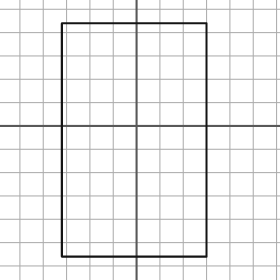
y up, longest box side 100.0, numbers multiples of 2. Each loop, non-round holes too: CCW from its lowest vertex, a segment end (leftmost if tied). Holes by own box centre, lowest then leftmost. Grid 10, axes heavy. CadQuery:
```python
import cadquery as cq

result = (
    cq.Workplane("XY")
    .moveTo(-32.0, -56.0)
    .lineTo(30.0, -56.0)
    .lineTo(30.0, 44.0)
    .lineTo(-32.0, 44.0)
    .close()
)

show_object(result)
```